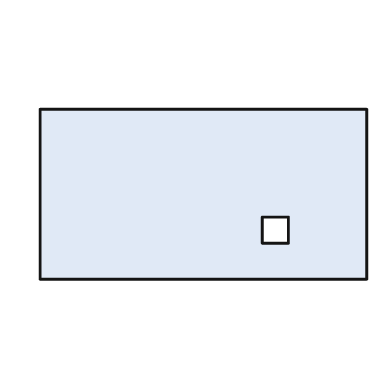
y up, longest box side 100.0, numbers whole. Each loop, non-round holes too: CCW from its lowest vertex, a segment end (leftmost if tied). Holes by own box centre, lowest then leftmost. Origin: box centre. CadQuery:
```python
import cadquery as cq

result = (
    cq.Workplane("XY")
    .moveTo(-50.0, -26.0)
    .lineTo(50.0, -26.0)
    .lineTo(50.0, 26.0)
    .lineTo(-50.0, 26.0)
    .close()
    .moveTo(18.0, -15.0)
    .lineTo(26.0, -15.0)
    .lineTo(26.0, -7.0)
    .lineTo(18.0, -7.0)
    .close()
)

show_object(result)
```